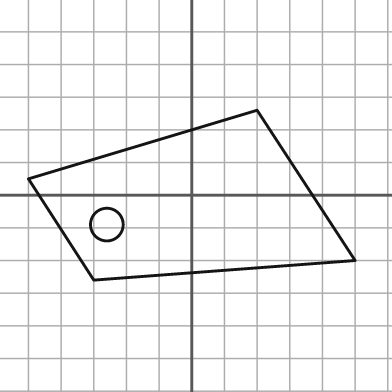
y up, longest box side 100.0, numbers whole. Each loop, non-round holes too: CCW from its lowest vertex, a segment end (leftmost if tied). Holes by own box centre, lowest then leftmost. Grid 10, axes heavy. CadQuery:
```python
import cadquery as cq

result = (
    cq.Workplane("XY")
    .moveTo(-30.0, -26.0)
    .lineTo(50.0, -20.0)
    .lineTo(20.0, 26.0)
    .lineTo(-50.0, 5.0)
    .close()
    .moveTo(-26.0, -9.0)
    .circle(5.0)
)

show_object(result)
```